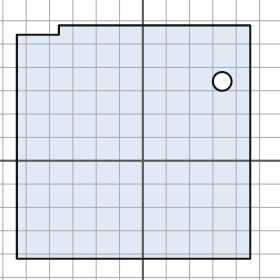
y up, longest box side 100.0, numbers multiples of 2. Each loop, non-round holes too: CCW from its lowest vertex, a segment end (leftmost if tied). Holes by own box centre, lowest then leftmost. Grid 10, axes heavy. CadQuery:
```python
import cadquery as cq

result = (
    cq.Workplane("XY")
    .moveTo(-54.0, -42.0)
    .lineTo(46.0, -42.0)
    .lineTo(46.0, 58.0)
    .lineTo(-36.0, 58.0)
    .lineTo(-36.0, 54.0)
    .lineTo(-54.0, 54.0)
    .close()
    .moveTo(34.0, 34.0)
    .circle(4.0)
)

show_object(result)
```